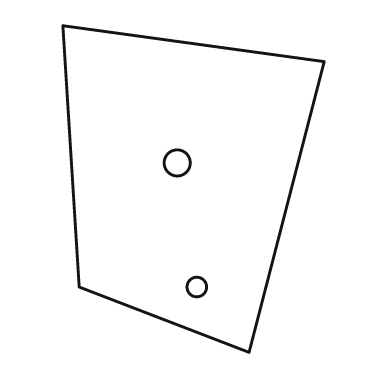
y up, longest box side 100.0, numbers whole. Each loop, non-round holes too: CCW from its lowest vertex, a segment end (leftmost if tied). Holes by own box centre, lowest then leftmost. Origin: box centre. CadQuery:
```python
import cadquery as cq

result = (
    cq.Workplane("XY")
    .moveTo(17.0, -50.0)
    .lineTo(40.0, 39.0)
    .lineTo(-40.0, 50.0)
    .lineTo(-35.0, -30.0)
    .close()
    .moveTo(1.0, -30.0)
    .circle(3.0)
    .moveTo(-5.0, 8.0)
    .circle(4.0)
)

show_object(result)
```